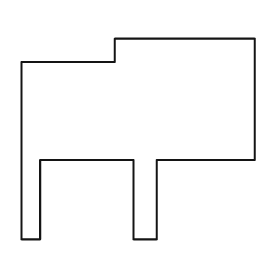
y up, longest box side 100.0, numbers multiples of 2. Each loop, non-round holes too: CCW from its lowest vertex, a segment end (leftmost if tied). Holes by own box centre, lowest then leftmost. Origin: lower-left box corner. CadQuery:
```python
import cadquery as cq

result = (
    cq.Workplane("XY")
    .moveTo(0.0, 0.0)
    .lineTo(8.0, 0.0)
    .lineTo(8.0, 34.0)
    .lineTo(48.0, 34.0)
    .lineTo(48.0, 0.0)
    .lineTo(58.0, 0.0)
    .lineTo(58.0, 34.0)
    .lineTo(100.0, 34.0)
    .lineTo(100.0, 86.0)
    .lineTo(40.0, 86.0)
    .lineTo(40.0, 76.0)
    .lineTo(0.0, 76.0)
    .close()
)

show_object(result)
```